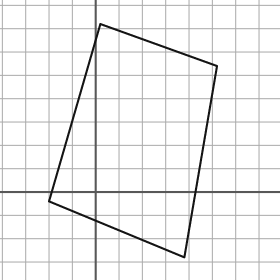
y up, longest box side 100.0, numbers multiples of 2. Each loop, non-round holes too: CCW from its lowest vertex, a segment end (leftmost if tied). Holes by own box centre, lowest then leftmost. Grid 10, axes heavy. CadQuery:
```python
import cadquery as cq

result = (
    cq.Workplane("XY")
    .moveTo(38.0, -28.0)
    .lineTo(52.0, 54.0)
    .lineTo(2.0, 72.0)
    .lineTo(-20.0, -4.0)
    .close()
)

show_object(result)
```